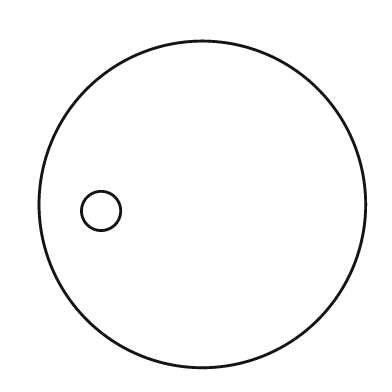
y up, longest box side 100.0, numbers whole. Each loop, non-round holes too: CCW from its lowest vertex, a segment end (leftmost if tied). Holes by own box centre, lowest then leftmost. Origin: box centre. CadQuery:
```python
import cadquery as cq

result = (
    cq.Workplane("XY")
    .moveTo(0.0, 0.0)
    .circle(50.0)
    .moveTo(-31.0, -2.0)
    .circle(6.0)
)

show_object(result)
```